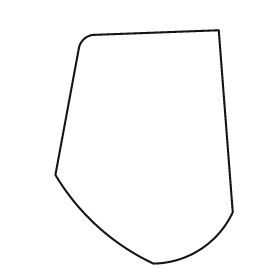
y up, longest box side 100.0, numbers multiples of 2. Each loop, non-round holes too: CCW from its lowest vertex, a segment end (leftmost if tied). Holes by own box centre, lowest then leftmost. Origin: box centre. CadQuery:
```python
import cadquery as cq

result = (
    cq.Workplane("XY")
    .moveTo(4.0, -50.0)
    .threePointArc((24.0, -44.0), (38.0, -28.0))
    .lineTo(32.0, 50.0)
    .lineTo(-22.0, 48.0)
    .threePointArc((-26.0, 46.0), (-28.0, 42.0))
    .lineTo(-38.0, -12.0)
    .threePointArc((-20.0, -34.0), (4.0, -50.0))
    .close()
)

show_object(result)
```